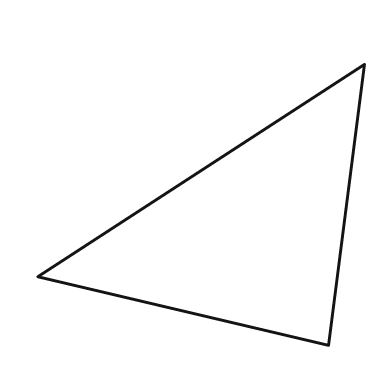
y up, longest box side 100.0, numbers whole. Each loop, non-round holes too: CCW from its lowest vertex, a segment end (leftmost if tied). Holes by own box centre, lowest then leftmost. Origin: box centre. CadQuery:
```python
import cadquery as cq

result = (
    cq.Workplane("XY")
    .moveTo(39.0, -43.0)
    .lineTo(50.0, 43.0)
    .lineTo(-50.0, -22.0)
    .close()
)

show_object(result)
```